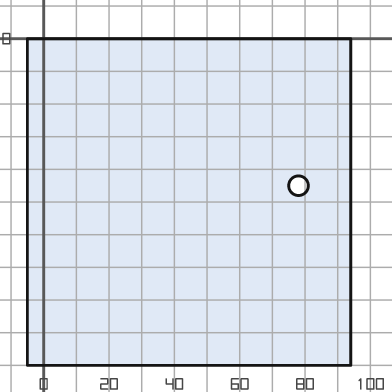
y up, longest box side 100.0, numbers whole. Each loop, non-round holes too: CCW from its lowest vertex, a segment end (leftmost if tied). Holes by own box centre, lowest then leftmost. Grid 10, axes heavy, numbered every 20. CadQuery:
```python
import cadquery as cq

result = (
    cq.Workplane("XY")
    .moveTo(-5.0, -100.0)
    .lineTo(94.0, -100.0)
    .lineTo(94.0, 0.0)
    .lineTo(-5.0, 0.0)
    .close()
    .moveTo(78.0, -45.0)
    .circle(3.0)
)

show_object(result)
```